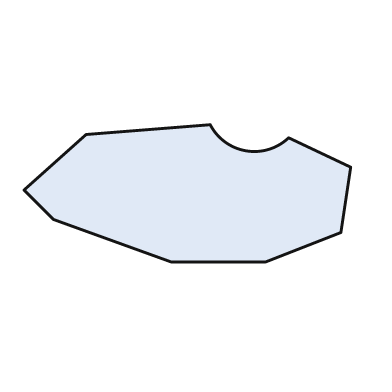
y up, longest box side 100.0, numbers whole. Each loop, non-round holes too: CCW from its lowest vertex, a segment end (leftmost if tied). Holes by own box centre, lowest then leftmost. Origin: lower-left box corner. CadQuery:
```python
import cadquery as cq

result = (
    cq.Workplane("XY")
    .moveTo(45.0, 0.0)
    .lineTo(74.0, 0.0)
    .lineTo(97.0, 9.0)
    .lineTo(100.0, 29.0)
    .lineTo(81.0, 38.0)
    .threePointArc((68.0, 34.0), (57.0, 42.0))
    .lineTo(19.0, 39.0)
    .lineTo(0.0, 22.0)
    .lineTo(9.0, 13.0)
    .close()
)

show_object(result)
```